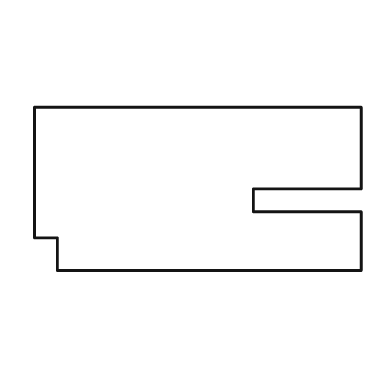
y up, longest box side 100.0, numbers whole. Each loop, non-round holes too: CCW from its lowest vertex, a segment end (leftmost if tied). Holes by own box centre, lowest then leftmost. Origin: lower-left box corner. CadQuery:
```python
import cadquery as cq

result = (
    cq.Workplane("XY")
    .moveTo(7.0, 0.0)
    .lineTo(100.0, 0.0)
    .lineTo(100.0, 18.0)
    .lineTo(67.0, 18.0)
    .lineTo(67.0, 25.0)
    .lineTo(100.0, 25.0)
    .lineTo(100.0, 50.0)
    .lineTo(0.0, 50.0)
    .lineTo(0.0, 10.0)
    .lineTo(7.0, 10.0)
    .close()
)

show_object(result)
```